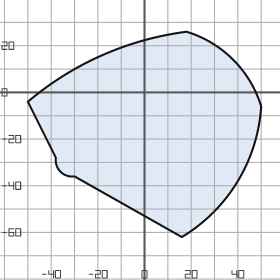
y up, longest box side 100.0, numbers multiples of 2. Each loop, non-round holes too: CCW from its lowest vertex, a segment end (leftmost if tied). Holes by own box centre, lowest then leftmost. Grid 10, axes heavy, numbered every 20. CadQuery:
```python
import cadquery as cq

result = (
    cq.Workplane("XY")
    .moveTo(16.0, -62.0)
    .threePointArc((40.0, -38.0), (50.0, -6.0))
    .threePointArc((38.0, 14.0), (18.0, 26.0))
    .threePointArc((-18.0, 16.0), (-50.0, -4.0))
    .lineTo(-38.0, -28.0)
    .threePointArc((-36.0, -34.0), (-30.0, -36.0))
    .close()
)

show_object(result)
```